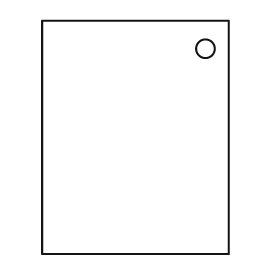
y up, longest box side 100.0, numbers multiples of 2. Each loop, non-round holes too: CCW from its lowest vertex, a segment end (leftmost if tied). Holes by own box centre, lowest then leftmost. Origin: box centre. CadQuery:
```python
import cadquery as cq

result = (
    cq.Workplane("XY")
    .moveTo(-40.0, -50.0)
    .lineTo(40.0, -50.0)
    .lineTo(40.0, 50.0)
    .lineTo(-40.0, 50.0)
    .close()
    .moveTo(30.0, 38.0)
    .circle(4.0)
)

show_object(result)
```